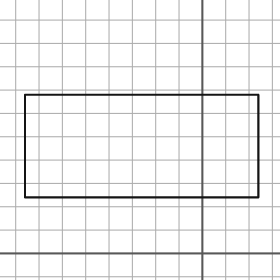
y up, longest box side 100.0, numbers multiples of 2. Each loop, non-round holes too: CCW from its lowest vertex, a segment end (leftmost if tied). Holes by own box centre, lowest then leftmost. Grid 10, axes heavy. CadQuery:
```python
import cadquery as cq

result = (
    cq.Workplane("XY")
    .moveTo(-76.0, 24.0)
    .lineTo(24.0, 24.0)
    .lineTo(24.0, 68.0)
    .lineTo(-76.0, 68.0)
    .close()
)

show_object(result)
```